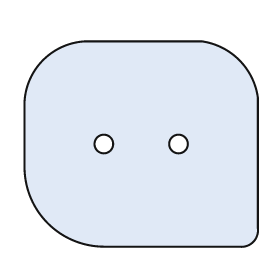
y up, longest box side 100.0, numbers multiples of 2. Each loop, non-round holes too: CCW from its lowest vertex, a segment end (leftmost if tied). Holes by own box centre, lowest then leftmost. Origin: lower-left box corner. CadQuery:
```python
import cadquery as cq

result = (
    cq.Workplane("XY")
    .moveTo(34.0, 0.0)
    .lineTo(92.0, 0.0)
    .threePointArc((98.0, 2.0), (100.0, 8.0))
    .lineTo(100.0, 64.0)
    .threePointArc((92.0, 80.0), (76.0, 88.0))
    .lineTo(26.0, 88.0)
    .threePointArc((8.0, 80.0), (0.0, 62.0))
    .lineTo(0.0, 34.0)
    .threePointArc((10.0, 10.0), (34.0, 0.0))
    .close()
    .moveTo(34.0, 44.0)
    .circle(4.0)
    .moveTo(66.0, 44.0)
    .circle(4.0)
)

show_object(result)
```